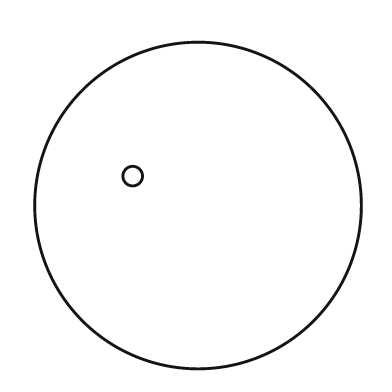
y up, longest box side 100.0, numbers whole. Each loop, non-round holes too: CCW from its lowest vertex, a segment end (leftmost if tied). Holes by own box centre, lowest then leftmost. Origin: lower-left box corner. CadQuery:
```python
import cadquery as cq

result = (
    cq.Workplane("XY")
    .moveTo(50.0, 50.0)
    .circle(50.0)
    .moveTo(30.0, 59.0)
    .circle(3.0)
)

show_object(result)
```